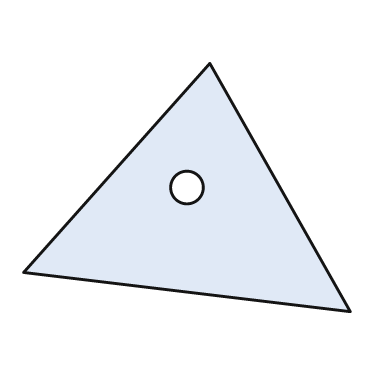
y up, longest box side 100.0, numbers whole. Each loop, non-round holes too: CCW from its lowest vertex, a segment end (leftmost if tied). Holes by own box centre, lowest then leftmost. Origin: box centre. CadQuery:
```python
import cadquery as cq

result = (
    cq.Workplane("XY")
    .moveTo(50.0, -38.0)
    .lineTo(7.0, 38.0)
    .lineTo(-50.0, -26.0)
    .close()
    .moveTo(0.0, 0.0)
    .circle(5.0)
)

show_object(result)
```